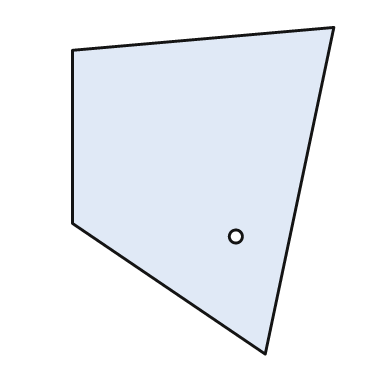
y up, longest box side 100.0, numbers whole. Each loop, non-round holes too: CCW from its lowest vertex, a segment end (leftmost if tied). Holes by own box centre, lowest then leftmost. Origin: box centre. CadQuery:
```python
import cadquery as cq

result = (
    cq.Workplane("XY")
    .moveTo(19.0, -50.0)
    .lineTo(40.0, 50.0)
    .lineTo(-40.0, 43.0)
    .lineTo(-40.0, -10.0)
    .close()
    .moveTo(10.0, -14.0)
    .circle(2.0)
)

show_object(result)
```